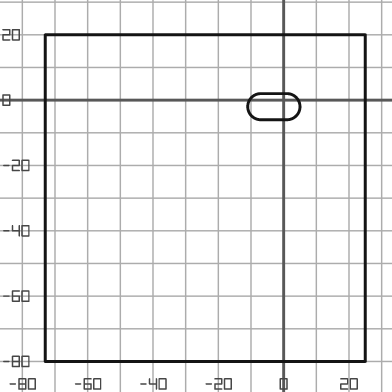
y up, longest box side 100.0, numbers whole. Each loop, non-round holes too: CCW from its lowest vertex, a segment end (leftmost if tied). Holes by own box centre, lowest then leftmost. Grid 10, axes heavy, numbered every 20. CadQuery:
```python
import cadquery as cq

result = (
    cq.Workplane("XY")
    .moveTo(-73.0, -80.0)
    .lineTo(25.0, -80.0)
    .lineTo(25.0, 20.0)
    .lineTo(-73.0, 20.0)
    .close()
    .moveTo(-7.0, -6.0)
    .lineTo(1.0, -6.0)
    .threePointArc((5.0, -2.0), (1.0, 2.0))
    .lineTo(-7.0, 2.0)
    .threePointArc((-11.0, -2.0), (-7.0, -6.0))
    .close()
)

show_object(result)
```